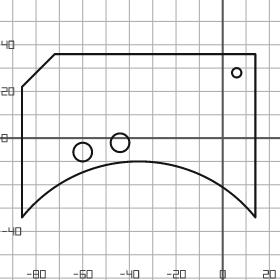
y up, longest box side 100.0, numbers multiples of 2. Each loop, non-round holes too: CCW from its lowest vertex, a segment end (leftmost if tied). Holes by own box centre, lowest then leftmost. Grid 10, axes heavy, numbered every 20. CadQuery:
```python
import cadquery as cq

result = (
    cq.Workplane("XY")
    .moveTo(-86.0, -34.0)
    .threePointArc((-36.0, -10.0), (14.0, -34.0))
    .lineTo(14.0, 36.0)
    .lineTo(-72.0, 36.0)
    .lineTo(-86.0, 22.0)
    .close()
    .moveTo(-60.0, -6.0)
    .circle(4.0)
    .moveTo(-44.0, -2.0)
    .circle(4.0)
    .moveTo(6.0, 28.0)
    .circle(2.0)
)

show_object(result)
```